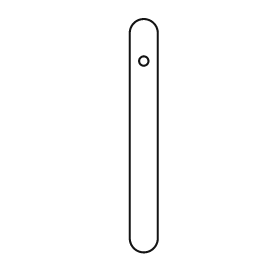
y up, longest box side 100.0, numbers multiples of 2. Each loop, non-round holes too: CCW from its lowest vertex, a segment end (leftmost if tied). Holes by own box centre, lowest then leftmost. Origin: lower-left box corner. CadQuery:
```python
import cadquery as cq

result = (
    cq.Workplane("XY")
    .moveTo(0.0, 6.0)
    .threePointArc((6.0, 0.0), (12.0, 6.0))
    .lineTo(12.0, 94.0)
    .threePointArc((6.0, 100.0), (0.0, 94.0))
    .close()
    .moveTo(6.0, 82.0)
    .circle(2.0)
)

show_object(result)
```